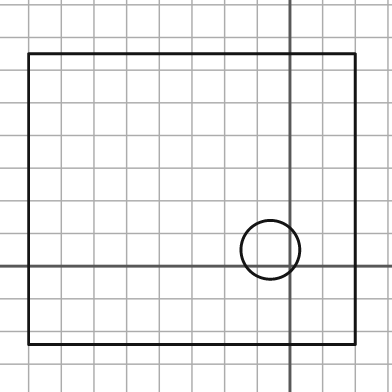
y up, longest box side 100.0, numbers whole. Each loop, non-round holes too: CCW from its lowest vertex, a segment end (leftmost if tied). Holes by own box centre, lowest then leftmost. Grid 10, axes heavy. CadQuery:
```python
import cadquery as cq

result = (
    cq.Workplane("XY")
    .moveTo(-80.0, -24.0)
    .lineTo(20.0, -24.0)
    .lineTo(20.0, 65.0)
    .lineTo(-80.0, 65.0)
    .close()
    .moveTo(-6.0, 5.0)
    .circle(9.0)
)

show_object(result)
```